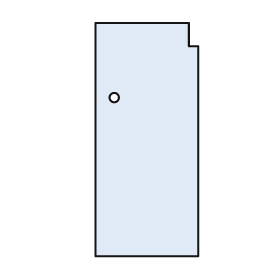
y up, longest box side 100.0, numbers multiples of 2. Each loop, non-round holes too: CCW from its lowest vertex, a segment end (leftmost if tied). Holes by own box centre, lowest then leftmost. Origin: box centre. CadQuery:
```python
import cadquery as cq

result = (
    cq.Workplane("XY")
    .moveTo(-22.0, -50.0)
    .lineTo(22.0, -50.0)
    .lineTo(22.0, 40.0)
    .lineTo(18.0, 40.0)
    .lineTo(18.0, 50.0)
    .lineTo(-22.0, 50.0)
    .close()
    .moveTo(-14.0, 18.0)
    .circle(2.0)
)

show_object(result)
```